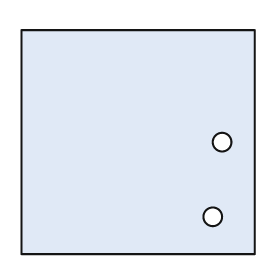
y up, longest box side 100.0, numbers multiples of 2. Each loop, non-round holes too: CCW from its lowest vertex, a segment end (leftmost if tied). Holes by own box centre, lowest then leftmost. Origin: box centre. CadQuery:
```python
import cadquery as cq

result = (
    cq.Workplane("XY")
    .moveTo(-50.0, -48.0)
    .lineTo(50.0, -48.0)
    .lineTo(50.0, 48.0)
    .lineTo(-50.0, 48.0)
    .close()
    .moveTo(32.0, -32.0)
    .circle(4.0)
    .moveTo(36.0, 0.0)
    .circle(4.0)
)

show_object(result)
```